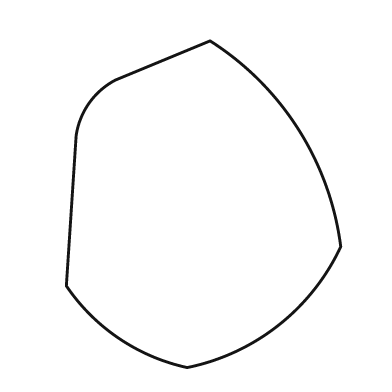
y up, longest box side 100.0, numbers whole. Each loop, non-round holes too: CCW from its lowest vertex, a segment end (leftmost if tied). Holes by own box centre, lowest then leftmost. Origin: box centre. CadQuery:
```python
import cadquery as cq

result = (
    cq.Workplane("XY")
    .moveTo(-5.0, -50.0)
    .threePointArc((23.0, -37.0), (42.0, -13.0))
    .threePointArc((29.0, 23.0), (2.0, 50.0))
    .lineTo(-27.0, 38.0)
    .threePointArc((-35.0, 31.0), (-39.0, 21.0))
    .lineTo(-42.0, -25.0)
    .threePointArc((-26.0, -41.0), (-5.0, -50.0))
    .close()
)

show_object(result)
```